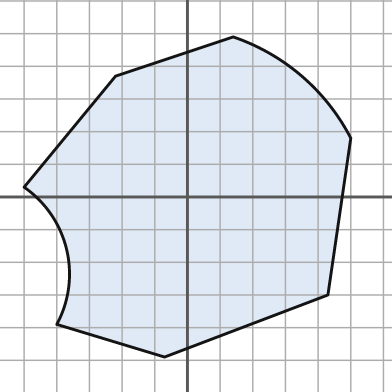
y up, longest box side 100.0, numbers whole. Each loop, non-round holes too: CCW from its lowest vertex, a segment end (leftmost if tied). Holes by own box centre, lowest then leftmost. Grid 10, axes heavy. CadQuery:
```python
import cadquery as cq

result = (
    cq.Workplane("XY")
    .moveTo(-7.0, -49.0)
    .lineTo(43.0, -30.0)
    .lineTo(50.0, 18.0)
    .threePointArc((35.0, 37.0), (14.0, 49.0))
    .lineTo(-22.0, 37.0)
    .lineTo(-50.0, 3.0)
    .threePointArc((-37.0, -16.0), (-40.0, -39.0))
    .close()
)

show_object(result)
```